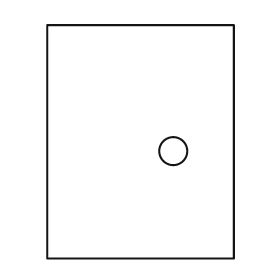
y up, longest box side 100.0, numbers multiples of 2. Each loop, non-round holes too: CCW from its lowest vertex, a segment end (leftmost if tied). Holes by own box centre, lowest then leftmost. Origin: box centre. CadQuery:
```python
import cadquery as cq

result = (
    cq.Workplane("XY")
    .moveTo(-40.0, -50.0)
    .lineTo(40.0, -50.0)
    .lineTo(40.0, 50.0)
    .lineTo(-40.0, 50.0)
    .close()
    .moveTo(14.0, -4.0)
    .circle(6.0)
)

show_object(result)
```